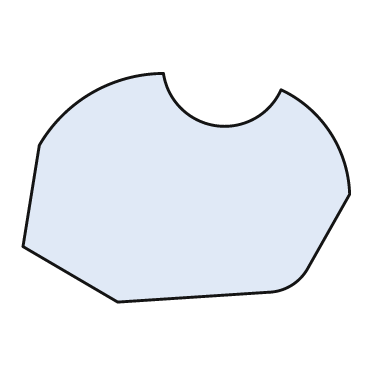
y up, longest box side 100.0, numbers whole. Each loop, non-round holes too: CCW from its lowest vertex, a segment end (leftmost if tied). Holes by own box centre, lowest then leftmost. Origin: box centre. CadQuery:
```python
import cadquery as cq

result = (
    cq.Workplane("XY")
    .moveTo(-21.0, -35.0)
    .lineTo(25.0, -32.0)
    .threePointArc((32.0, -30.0), (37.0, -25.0))
    .lineTo(50.0, -2.0)
    .threePointArc((44.0, 17.0), (29.0, 30.0))
    .threePointArc((9.0, 19.0), (-7.0, 35.0))
    .threePointArc((-29.0, 29.0), (-45.0, 13.0))
    .lineTo(-50.0, -18.0)
    .close()
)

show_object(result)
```